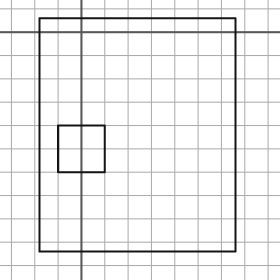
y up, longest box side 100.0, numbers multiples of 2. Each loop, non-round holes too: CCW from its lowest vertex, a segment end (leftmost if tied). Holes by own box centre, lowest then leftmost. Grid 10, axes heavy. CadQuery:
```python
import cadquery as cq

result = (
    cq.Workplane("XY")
    .moveTo(-18.0, -94.0)
    .lineTo(66.0, -94.0)
    .lineTo(66.0, 6.0)
    .lineTo(-18.0, 6.0)
    .close()
    .moveTo(-10.0, -60.0)
    .lineTo(10.0, -60.0)
    .lineTo(10.0, -40.0)
    .lineTo(-10.0, -40.0)
    .close()
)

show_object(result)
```